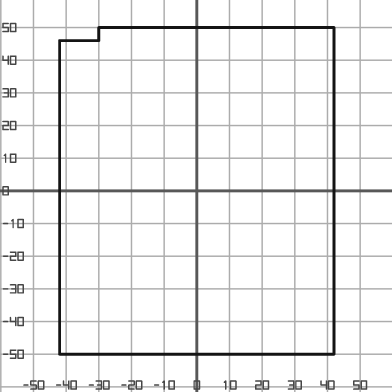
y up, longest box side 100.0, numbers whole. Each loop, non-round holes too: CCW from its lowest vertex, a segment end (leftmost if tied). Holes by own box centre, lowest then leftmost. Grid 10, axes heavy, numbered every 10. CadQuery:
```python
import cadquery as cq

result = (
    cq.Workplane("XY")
    .moveTo(-42.0, -50.0)
    .lineTo(42.0, -50.0)
    .lineTo(42.0, 50.0)
    .lineTo(-30.0, 50.0)
    .lineTo(-30.0, 46.0)
    .lineTo(-42.0, 46.0)
    .close()
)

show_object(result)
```